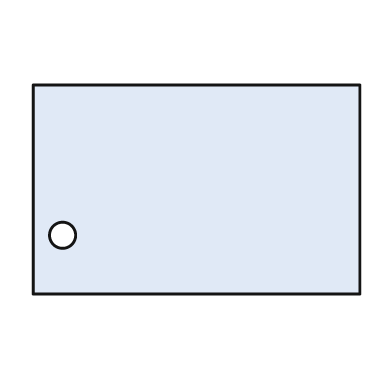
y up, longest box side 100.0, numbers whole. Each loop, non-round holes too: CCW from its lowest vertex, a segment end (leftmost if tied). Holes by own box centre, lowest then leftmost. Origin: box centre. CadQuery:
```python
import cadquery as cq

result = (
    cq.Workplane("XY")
    .moveTo(-50.0, -32.0)
    .lineTo(50.0, -32.0)
    .lineTo(50.0, 32.0)
    .lineTo(-50.0, 32.0)
    .close()
    .moveTo(-41.0, -14.0)
    .circle(4.0)
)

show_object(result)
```